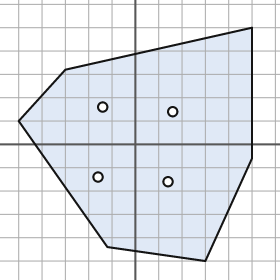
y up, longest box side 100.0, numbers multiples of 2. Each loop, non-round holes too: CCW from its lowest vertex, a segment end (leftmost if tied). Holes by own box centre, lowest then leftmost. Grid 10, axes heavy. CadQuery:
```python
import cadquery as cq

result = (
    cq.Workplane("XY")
    .moveTo(30.0, -50.0)
    .lineTo(50.0, -6.0)
    .lineTo(50.0, 50.0)
    .lineTo(-30.0, 32.0)
    .lineTo(-50.0, 10.0)
    .lineTo(-12.0, -44.0)
    .close()
    .moveTo(14.0, -16.0)
    .circle(2.0)
    .moveTo(-16.0, -14.0)
    .circle(2.0)
    .moveTo(16.0, 14.0)
    .circle(2.0)
    .moveTo(-14.0, 16.0)
    .circle(2.0)
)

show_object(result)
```